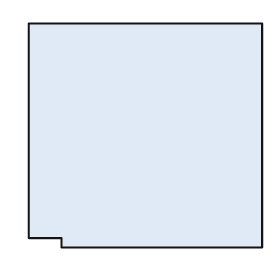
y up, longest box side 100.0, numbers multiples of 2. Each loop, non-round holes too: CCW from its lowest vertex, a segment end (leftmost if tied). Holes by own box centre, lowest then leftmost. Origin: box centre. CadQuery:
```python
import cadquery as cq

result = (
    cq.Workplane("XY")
    .moveTo(-36.0, -48.0)
    .lineTo(50.0, -48.0)
    .lineTo(50.0, 48.0)
    .lineTo(-50.0, 48.0)
    .lineTo(-50.0, -44.0)
    .lineTo(-36.0, -44.0)
    .close()
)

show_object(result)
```